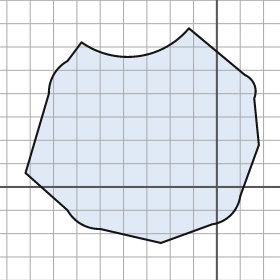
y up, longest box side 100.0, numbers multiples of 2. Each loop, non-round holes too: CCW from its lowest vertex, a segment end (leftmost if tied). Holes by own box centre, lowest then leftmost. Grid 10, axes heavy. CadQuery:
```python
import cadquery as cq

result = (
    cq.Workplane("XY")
    .moveTo(-24.0, -24.0)
    .lineTo(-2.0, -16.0)
    .threePointArc((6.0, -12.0), (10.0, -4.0))
    .lineTo(18.0, 18.0)
    .lineTo(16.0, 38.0)
    .threePointArc((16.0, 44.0), (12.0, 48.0))
    .lineTo(-12.0, 68.0)
    .threePointArc((-34.0, 56.0), (-58.0, 62.0))
    .lineTo(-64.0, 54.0)
    .threePointArc((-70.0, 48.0), (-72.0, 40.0))
    .lineTo(-82.0, 6.0)
    .lineTo(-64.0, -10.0)
    .threePointArc((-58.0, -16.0), (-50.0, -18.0))
    .close()
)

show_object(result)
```